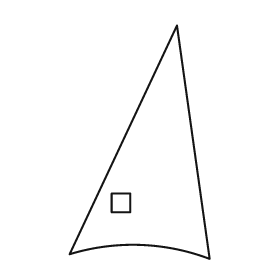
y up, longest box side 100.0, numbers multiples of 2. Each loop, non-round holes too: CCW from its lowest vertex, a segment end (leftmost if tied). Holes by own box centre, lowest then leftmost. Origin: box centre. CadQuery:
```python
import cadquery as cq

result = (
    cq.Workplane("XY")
    .moveTo(30.0, -50.0)
    .lineTo(16.0, 50.0)
    .lineTo(-30.0, -48.0)
    .threePointArc((0.0, -44.0), (30.0, -50.0))
    .close()
    .moveTo(-12.0, -30.0)
    .lineTo(-4.0, -30.0)
    .lineTo(-4.0, -22.0)
    .lineTo(-12.0, -22.0)
    .close()
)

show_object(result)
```